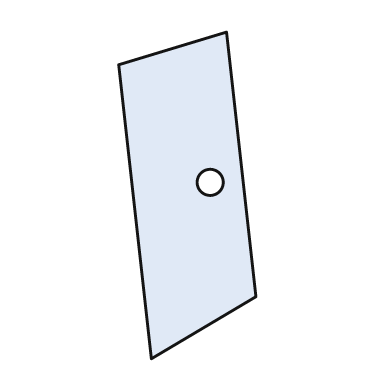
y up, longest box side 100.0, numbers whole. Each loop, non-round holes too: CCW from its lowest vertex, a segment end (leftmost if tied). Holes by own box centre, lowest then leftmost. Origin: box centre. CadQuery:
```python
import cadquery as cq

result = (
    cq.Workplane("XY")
    .moveTo(-11.0, -50.0)
    .lineTo(21.0, -31.0)
    .lineTo(12.0, 50.0)
    .lineTo(-21.0, 40.0)
    .close()
    .moveTo(7.0, 4.0)
    .circle(4.0)
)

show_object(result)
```